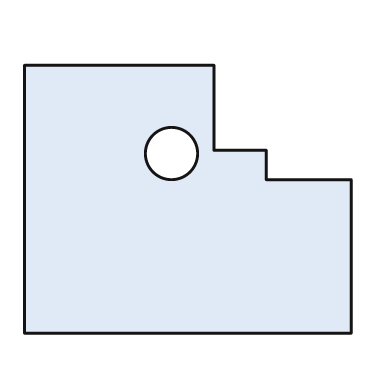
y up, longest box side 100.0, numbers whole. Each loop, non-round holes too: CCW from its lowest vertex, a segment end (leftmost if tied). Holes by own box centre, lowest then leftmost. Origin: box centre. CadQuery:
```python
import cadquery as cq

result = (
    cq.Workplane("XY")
    .moveTo(-50.0, -41.0)
    .lineTo(50.0, -41.0)
    .lineTo(50.0, 6.0)
    .lineTo(24.0, 6.0)
    .lineTo(24.0, 15.0)
    .lineTo(8.0, 15.0)
    .lineTo(8.0, 41.0)
    .lineTo(-50.0, 41.0)
    .close()
    .moveTo(-5.0, 14.0)
    .circle(8.0)
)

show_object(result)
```